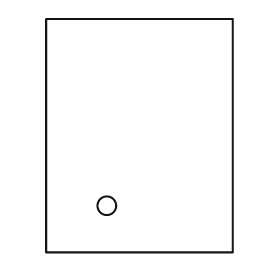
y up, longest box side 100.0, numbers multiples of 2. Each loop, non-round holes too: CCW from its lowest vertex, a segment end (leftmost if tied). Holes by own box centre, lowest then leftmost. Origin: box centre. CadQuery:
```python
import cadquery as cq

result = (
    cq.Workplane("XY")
    .moveTo(-40.0, -50.0)
    .lineTo(40.0, -50.0)
    .lineTo(40.0, 50.0)
    .lineTo(-40.0, 50.0)
    .close()
    .moveTo(-14.0, -30.0)
    .circle(4.0)
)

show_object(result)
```